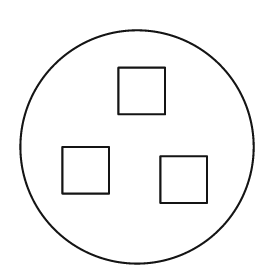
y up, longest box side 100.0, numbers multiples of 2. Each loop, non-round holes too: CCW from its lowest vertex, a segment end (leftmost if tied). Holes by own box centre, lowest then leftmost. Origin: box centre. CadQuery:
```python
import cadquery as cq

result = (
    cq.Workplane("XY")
    .moveTo(0.0, 0.0)
    .circle(50.0)
    .moveTo(10.0, -24.0)
    .lineTo(30.0, -24.0)
    .lineTo(30.0, -4.0)
    .lineTo(10.0, -4.0)
    .close()
    .moveTo(-32.0, -20.0)
    .lineTo(-12.0, -20.0)
    .lineTo(-12.0, 0.0)
    .lineTo(-32.0, 0.0)
    .close()
    .moveTo(-8.0, 14.0)
    .lineTo(12.0, 14.0)
    .lineTo(12.0, 34.0)
    .lineTo(-8.0, 34.0)
    .close()
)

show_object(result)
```